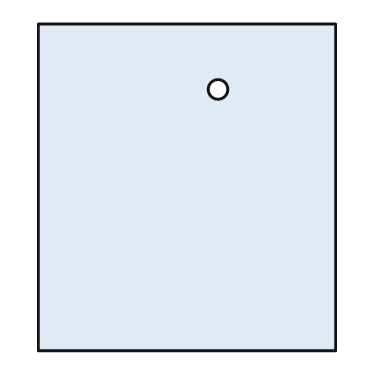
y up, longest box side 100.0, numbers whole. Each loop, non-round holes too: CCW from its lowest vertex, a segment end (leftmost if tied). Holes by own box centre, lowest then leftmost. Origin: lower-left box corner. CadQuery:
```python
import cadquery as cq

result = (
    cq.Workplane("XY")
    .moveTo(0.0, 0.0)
    .lineTo(91.0, 0.0)
    .lineTo(91.0, 100.0)
    .lineTo(0.0, 100.0)
    .close()
    .moveTo(55.0, 80.0)
    .circle(3.0)
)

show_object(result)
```